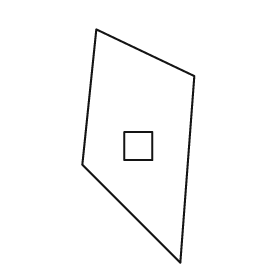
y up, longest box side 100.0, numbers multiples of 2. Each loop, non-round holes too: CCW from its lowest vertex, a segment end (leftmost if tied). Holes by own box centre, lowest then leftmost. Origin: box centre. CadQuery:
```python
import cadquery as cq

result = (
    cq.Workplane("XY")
    .moveTo(18.0, -50.0)
    .lineTo(24.0, 30.0)
    .lineTo(-18.0, 50.0)
    .lineTo(-24.0, -8.0)
    .close()
    .moveTo(-6.0, -6.0)
    .lineTo(6.0, -6.0)
    .lineTo(6.0, 6.0)
    .lineTo(-6.0, 6.0)
    .close()
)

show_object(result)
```